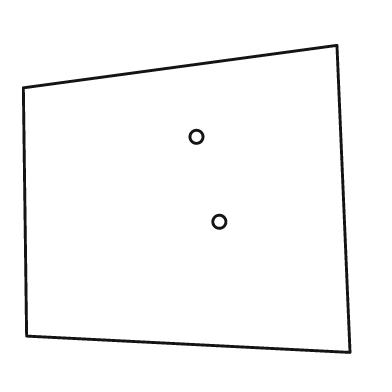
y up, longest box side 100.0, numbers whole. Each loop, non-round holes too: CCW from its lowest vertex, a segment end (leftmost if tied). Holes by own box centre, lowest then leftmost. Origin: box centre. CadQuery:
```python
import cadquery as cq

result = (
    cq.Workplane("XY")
    .moveTo(50.0, -47.0)
    .lineTo(46.0, 47.0)
    .lineTo(-50.0, 34.0)
    .lineTo(-49.0, -42.0)
    .close()
    .moveTo(10.0, -7.0)
    .circle(2.0)
    .moveTo(3.0, 19.0)
    .circle(2.0)
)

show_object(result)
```